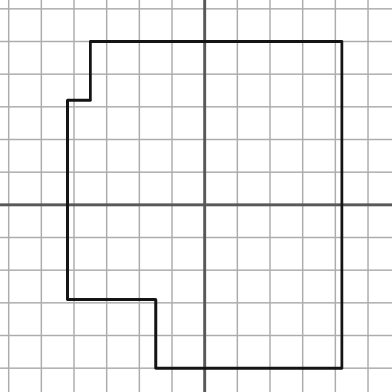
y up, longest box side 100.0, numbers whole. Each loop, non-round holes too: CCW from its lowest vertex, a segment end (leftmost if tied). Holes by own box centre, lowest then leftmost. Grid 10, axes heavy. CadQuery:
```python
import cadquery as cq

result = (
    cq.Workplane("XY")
    .moveTo(-15.0, -50.0)
    .lineTo(42.0, -50.0)
    .lineTo(42.0, 50.0)
    .lineTo(-35.0, 50.0)
    .lineTo(-35.0, 32.0)
    .lineTo(-42.0, 32.0)
    .lineTo(-42.0, -29.0)
    .lineTo(-15.0, -29.0)
    .close()
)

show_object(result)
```